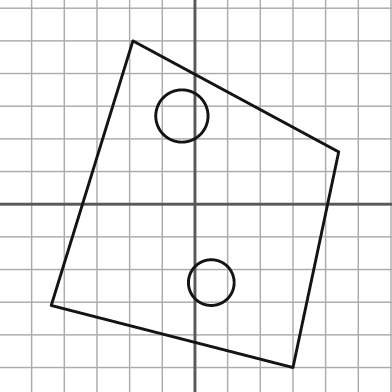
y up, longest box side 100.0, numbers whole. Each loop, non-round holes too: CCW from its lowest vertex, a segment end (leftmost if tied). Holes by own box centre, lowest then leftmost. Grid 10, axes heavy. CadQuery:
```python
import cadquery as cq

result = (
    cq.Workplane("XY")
    .moveTo(30.0, -50.0)
    .lineTo(44.0, 16.0)
    .lineTo(-19.0, 50.0)
    .lineTo(-44.0, -31.0)
    .close()
    .moveTo(5.0, -24.0)
    .circle(7.0)
    .moveTo(-4.0, 27.0)
    .circle(8.0)
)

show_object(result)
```